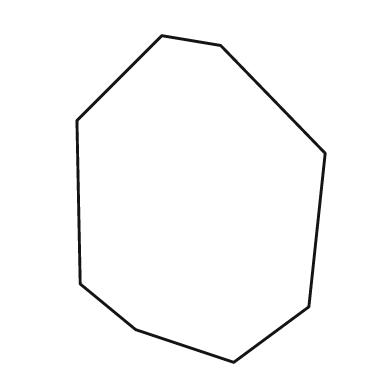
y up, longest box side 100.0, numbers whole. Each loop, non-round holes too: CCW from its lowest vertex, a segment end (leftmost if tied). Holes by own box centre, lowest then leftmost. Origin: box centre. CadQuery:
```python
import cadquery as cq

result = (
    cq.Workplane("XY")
    .moveTo(10.0, -50.0)
    .lineTo(33.0, -33.0)
    .lineTo(38.0, 14.0)
    .lineTo(6.0, 47.0)
    .lineTo(-12.0, 50.0)
    .lineTo(-38.0, 24.0)
    .lineTo(-37.0, -26.0)
    .lineTo(-20.0, -40.0)
    .close()
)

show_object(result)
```